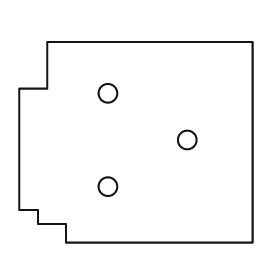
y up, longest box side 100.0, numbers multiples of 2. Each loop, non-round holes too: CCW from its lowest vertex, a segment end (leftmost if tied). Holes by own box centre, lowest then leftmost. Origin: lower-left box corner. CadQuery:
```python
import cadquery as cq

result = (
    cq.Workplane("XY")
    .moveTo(20.0, 0.0)
    .lineTo(100.0, 0.0)
    .lineTo(100.0, 86.0)
    .lineTo(12.0, 86.0)
    .lineTo(12.0, 66.0)
    .lineTo(0.0, 66.0)
    .lineTo(0.0, 14.0)
    .lineTo(8.0, 14.0)
    .lineTo(8.0, 8.0)
    .lineTo(20.0, 8.0)
    .close()
    .moveTo(38.0, 24.0)
    .circle(4.0)
    .moveTo(72.0, 44.0)
    .circle(4.0)
    .moveTo(38.0, 64.0)
    .circle(4.0)
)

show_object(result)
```